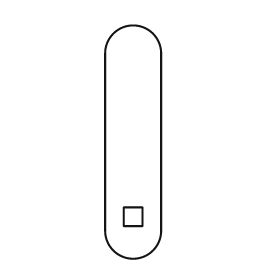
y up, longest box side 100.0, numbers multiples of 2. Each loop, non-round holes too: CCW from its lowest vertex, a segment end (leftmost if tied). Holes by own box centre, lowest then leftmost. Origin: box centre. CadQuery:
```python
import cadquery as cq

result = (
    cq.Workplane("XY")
    .moveTo(-12.0, -38.0)
    .threePointArc((0.0, -50.0), (12.0, -38.0))
    .lineTo(12.0, 38.0)
    .threePointArc((0.0, 50.0), (-12.0, 38.0))
    .close()
    .moveTo(-4.0, -36.0)
    .lineTo(4.0, -36.0)
    .lineTo(4.0, -28.0)
    .lineTo(-4.0, -28.0)
    .close()
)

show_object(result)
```